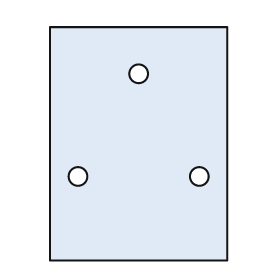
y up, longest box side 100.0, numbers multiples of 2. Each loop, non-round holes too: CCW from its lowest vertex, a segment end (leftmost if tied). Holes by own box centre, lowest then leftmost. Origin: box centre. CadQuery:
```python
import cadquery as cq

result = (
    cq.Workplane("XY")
    .moveTo(-38.0, -50.0)
    .lineTo(38.0, -50.0)
    .lineTo(38.0, 50.0)
    .lineTo(-38.0, 50.0)
    .close()
    .moveTo(-26.0, -14.0)
    .circle(4.0)
    .moveTo(26.0, -14.0)
    .circle(4.0)
    .moveTo(0.0, 30.0)
    .circle(4.0)
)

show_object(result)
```